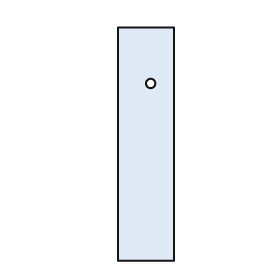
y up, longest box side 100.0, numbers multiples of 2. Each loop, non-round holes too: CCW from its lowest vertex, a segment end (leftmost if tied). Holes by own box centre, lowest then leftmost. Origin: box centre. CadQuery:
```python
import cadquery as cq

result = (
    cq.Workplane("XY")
    .moveTo(-12.0, -50.0)
    .lineTo(12.0, -50.0)
    .lineTo(12.0, 50.0)
    .lineTo(-12.0, 50.0)
    .close()
    .moveTo(2.0, 26.0)
    .circle(2.0)
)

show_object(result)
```